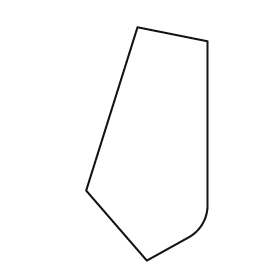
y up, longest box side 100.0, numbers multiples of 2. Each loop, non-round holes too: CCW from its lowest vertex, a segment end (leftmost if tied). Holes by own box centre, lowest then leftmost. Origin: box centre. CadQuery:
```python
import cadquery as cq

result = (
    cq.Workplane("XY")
    .moveTo(0.0, -50.0)
    .lineTo(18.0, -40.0)
    .threePointArc((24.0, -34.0), (26.0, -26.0))
    .lineTo(26.0, 44.0)
    .lineTo(-4.0, 50.0)
    .lineTo(-26.0, -20.0)
    .close()
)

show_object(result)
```